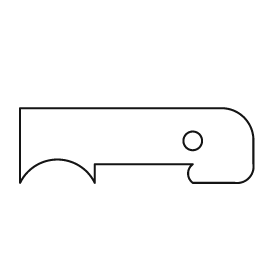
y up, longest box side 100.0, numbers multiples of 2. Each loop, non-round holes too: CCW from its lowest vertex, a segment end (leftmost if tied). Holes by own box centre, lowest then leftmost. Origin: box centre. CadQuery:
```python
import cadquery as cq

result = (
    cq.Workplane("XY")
    .moveTo(-50.0, -16.0)
    .threePointArc((-34.0, -6.0), (-18.0, -16.0))
    .lineTo(-18.0, -8.0)
    .lineTo(24.0, -8.0)
    .threePointArc((22.0, -12.0), (24.0, -16.0))
    .lineTo(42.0, -16.0)
    .threePointArc((48.0, -14.0), (50.0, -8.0))
    .lineTo(50.0, 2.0)
    .threePointArc((46.0, 12.0), (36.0, 16.0))
    .lineTo(-50.0, 16.0)
    .close()
    .moveTo(24.0, 2.0)
    .circle(4.0)
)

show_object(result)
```